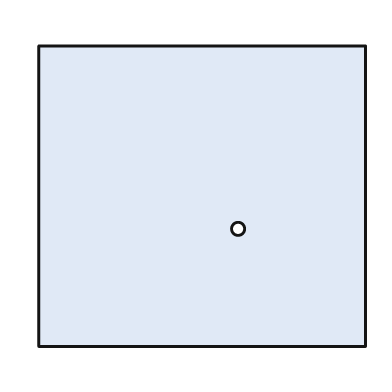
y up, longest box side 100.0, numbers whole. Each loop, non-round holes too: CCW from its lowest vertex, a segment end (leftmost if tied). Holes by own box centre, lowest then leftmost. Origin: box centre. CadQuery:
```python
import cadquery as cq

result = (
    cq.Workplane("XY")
    .moveTo(-50.0, -46.0)
    .lineTo(50.0, -46.0)
    .lineTo(50.0, 46.0)
    .lineTo(-50.0, 46.0)
    .close()
    .moveTo(11.0, -10.0)
    .circle(2.0)
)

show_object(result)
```